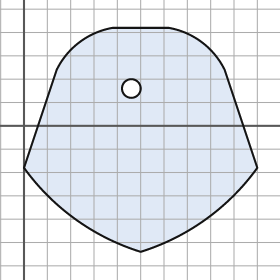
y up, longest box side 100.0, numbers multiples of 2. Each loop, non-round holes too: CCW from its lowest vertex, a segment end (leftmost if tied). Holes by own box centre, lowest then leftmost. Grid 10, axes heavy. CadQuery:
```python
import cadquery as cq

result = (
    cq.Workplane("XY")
    .moveTo(50.0, -54.0)
    .threePointArc((78.0, -40.0), (100.0, -18.0))
    .lineTo(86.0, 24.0)
    .threePointArc((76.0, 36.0), (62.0, 42.0))
    .lineTo(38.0, 42.0)
    .threePointArc((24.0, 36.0), (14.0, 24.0))
    .lineTo(0.0, -18.0)
    .threePointArc((22.0, -40.0), (50.0, -54.0))
    .close()
    .moveTo(46.0, 16.0)
    .circle(4.0)
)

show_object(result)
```